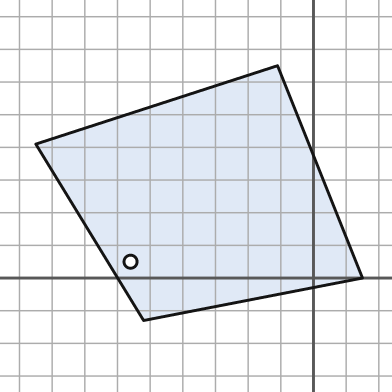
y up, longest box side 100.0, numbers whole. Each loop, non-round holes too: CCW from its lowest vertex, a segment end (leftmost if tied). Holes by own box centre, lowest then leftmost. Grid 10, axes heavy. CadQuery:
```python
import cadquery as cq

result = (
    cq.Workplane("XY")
    .moveTo(-52.0, -13.0)
    .lineTo(15.0, 0.0)
    .lineTo(-11.0, 65.0)
    .lineTo(-85.0, 41.0)
    .close()
    .moveTo(-56.0, 5.0)
    .circle(2.0)
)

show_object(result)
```